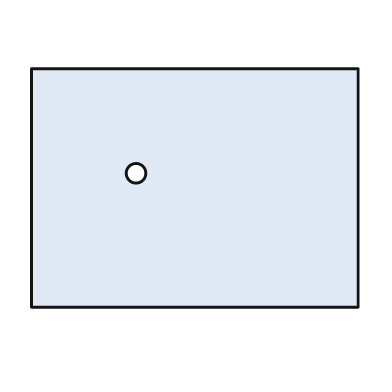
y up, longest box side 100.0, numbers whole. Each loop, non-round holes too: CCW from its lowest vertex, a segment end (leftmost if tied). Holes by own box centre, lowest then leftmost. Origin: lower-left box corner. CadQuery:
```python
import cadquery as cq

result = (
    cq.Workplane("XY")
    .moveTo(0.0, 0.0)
    .lineTo(100.0, 0.0)
    .lineTo(100.0, 73.0)
    .lineTo(0.0, 73.0)
    .close()
    .moveTo(32.0, 41.0)
    .circle(3.0)
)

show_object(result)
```